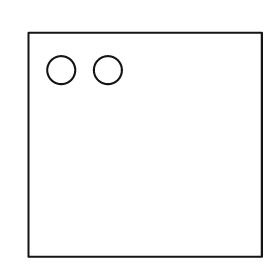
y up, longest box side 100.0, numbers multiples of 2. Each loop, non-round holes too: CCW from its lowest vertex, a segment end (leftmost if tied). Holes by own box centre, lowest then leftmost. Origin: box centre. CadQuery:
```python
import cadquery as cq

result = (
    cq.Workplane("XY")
    .moveTo(-50.0, -48.0)
    .lineTo(50.0, -48.0)
    .lineTo(50.0, 48.0)
    .lineTo(-50.0, 48.0)
    .close()
    .moveTo(-36.0, 32.0)
    .circle(6.0)
    .moveTo(-16.0, 32.0)
    .circle(6.0)
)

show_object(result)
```